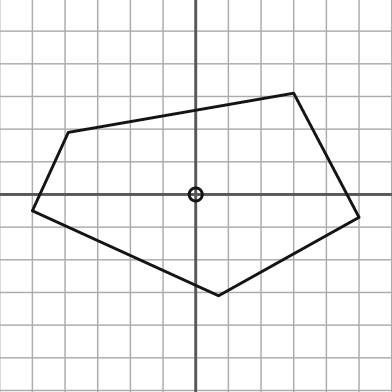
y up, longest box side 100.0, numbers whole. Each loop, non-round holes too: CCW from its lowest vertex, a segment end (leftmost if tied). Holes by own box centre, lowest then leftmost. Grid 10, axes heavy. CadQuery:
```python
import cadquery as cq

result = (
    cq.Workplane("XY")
    .moveTo(7.0, -31.0)
    .lineTo(50.0, -7.0)
    .lineTo(30.0, 31.0)
    .lineTo(-39.0, 19.0)
    .lineTo(-50.0, -5.0)
    .close()
    .moveTo(0.0, 0.0)
    .circle(2.0)
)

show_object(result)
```